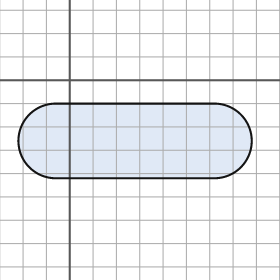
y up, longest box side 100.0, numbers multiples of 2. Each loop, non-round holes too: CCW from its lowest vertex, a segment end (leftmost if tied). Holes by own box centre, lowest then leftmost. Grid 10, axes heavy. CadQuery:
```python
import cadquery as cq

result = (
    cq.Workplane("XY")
    .moveTo(-6.0, -42.0)
    .lineTo(62.0, -42.0)
    .threePointArc((78.0, -26.0), (62.0, -10.0))
    .lineTo(-6.0, -10.0)
    .threePointArc((-22.0, -26.0), (-6.0, -42.0))
    .close()
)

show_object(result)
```